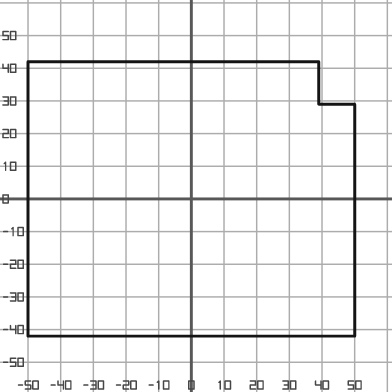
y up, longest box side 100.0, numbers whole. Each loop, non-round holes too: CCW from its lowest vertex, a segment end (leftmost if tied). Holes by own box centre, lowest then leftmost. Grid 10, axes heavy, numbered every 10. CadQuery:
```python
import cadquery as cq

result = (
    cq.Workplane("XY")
    .moveTo(-50.0, -42.0)
    .lineTo(50.0, -42.0)
    .lineTo(50.0, 29.0)
    .lineTo(39.0, 29.0)
    .lineTo(39.0, 42.0)
    .lineTo(-50.0, 42.0)
    .close()
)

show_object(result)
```